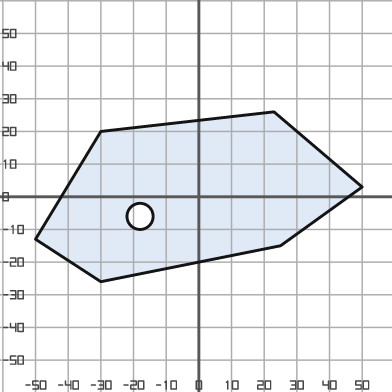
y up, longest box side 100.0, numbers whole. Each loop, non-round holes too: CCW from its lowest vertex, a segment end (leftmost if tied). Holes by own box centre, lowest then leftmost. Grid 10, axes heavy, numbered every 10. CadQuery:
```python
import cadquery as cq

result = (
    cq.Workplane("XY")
    .moveTo(-30.0, -26.0)
    .lineTo(25.0, -15.0)
    .lineTo(50.0, 3.0)
    .lineTo(23.0, 26.0)
    .lineTo(-30.0, 20.0)
    .lineTo(-50.0, -13.0)
    .close()
    .moveTo(-18.0, -6.0)
    .circle(4.0)
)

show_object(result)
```